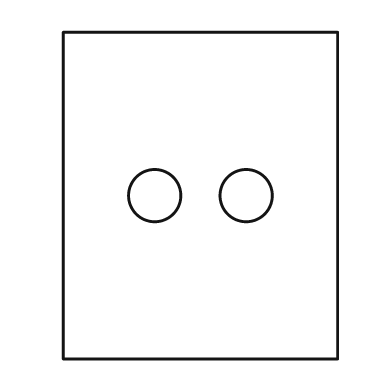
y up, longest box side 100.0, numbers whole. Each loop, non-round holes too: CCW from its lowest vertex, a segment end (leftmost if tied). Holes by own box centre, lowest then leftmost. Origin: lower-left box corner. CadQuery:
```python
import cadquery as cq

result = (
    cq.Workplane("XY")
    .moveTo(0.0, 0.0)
    .lineTo(84.0, 0.0)
    .lineTo(84.0, 100.0)
    .lineTo(0.0, 100.0)
    .close()
    .moveTo(28.0, 50.0)
    .circle(8.0)
    .moveTo(56.0, 50.0)
    .circle(8.0)
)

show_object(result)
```